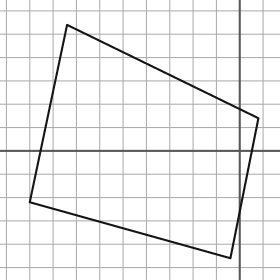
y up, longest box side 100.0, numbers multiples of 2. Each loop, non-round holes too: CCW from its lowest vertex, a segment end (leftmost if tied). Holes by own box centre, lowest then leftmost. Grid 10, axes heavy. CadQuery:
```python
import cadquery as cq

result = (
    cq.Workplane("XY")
    .moveTo(-4.0, -46.0)
    .lineTo(8.0, 14.0)
    .lineTo(-74.0, 54.0)
    .lineTo(-90.0, -22.0)
    .close()
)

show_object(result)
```